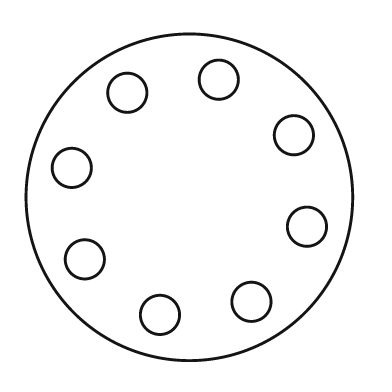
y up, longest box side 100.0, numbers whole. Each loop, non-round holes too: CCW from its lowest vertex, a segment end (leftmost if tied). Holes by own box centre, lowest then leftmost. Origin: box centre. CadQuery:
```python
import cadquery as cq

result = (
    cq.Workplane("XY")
    .moveTo(0.0, 0.0)
    .circle(50.0)
    .moveTo(-9.0, -36.0)
    .circle(6.0)
    .moveTo(19.0, -32.0)
    .circle(6.0)
    .moveTo(-32.0, -19.0)
    .circle(6.0)
    .moveTo(36.0, -9.0)
    .circle(6.0)
    .moveTo(-36.0, 9.0)
    .circle(6.0)
    .moveTo(32.0, 19.0)
    .circle(6.0)
    .moveTo(-19.0, 32.0)
    .circle(6.0)
    .moveTo(9.0, 36.0)
    .circle(6.0)
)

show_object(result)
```